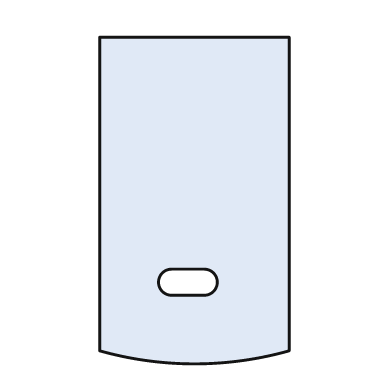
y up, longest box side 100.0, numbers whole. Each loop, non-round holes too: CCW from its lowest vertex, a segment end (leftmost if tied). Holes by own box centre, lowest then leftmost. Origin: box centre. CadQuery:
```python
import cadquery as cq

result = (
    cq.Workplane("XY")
    .moveTo(-29.0, -46.0)
    .threePointArc((0.0, -50.0), (29.0, -46.0))
    .lineTo(29.0, 50.0)
    .lineTo(-29.0, 50.0)
    .close()
    .moveTo(-7.0, -29.0)
    .lineTo(3.0, -29.0)
    .threePointArc((7.0, -25.0), (3.0, -21.0))
    .lineTo(-7.0, -21.0)
    .threePointArc((-11.0, -25.0), (-7.0, -29.0))
    .close()
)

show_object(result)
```